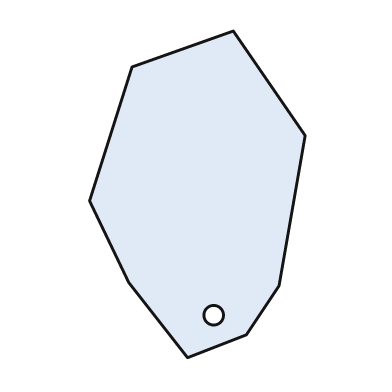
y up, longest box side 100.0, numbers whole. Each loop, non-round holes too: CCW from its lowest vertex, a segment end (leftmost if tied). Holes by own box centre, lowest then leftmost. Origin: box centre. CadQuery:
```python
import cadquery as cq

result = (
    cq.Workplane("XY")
    .moveTo(-3.0, -50.0)
    .lineTo(15.0, -43.0)
    .lineTo(25.0, -28.0)
    .lineTo(33.0, 18.0)
    .lineTo(11.0, 50.0)
    .lineTo(-20.0, 39.0)
    .lineTo(-33.0, -2.0)
    .lineTo(-21.0, -27.0)
    .close()
    .moveTo(5.0, -37.0)
    .circle(3.0)
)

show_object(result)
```